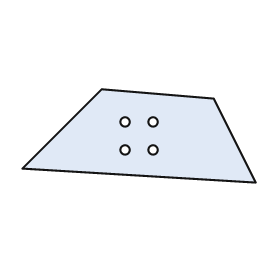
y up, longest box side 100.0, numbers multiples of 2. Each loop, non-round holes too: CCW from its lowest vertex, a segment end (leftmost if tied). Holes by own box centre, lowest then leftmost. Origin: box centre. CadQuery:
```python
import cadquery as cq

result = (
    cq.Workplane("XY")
    .moveTo(50.0, -20.0)
    .lineTo(32.0, 16.0)
    .lineTo(-16.0, 20.0)
    .lineTo(-50.0, -14.0)
    .close()
    .moveTo(-6.0, -6.0)
    .circle(2.0)
    .moveTo(6.0, -6.0)
    .circle(2.0)
    .moveTo(-6.0, 6.0)
    .circle(2.0)
    .moveTo(6.0, 6.0)
    .circle(2.0)
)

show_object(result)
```